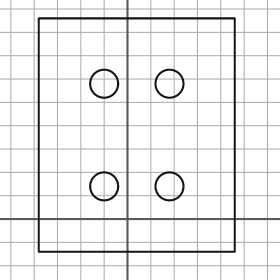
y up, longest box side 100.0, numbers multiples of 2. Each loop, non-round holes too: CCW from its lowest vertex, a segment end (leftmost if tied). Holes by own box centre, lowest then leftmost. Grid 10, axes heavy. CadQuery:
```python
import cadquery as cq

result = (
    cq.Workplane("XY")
    .moveTo(-38.0, -14.0)
    .lineTo(46.0, -14.0)
    .lineTo(46.0, 86.0)
    .lineTo(-38.0, 86.0)
    .close()
    .moveTo(-10.0, 14.0)
    .circle(6.0)
    .moveTo(18.0, 14.0)
    .circle(6.0)
    .moveTo(-10.0, 58.0)
    .circle(6.0)
    .moveTo(18.0, 58.0)
    .circle(6.0)
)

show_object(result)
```